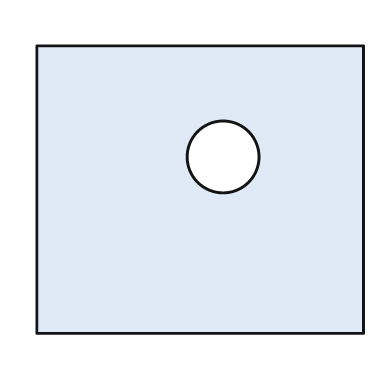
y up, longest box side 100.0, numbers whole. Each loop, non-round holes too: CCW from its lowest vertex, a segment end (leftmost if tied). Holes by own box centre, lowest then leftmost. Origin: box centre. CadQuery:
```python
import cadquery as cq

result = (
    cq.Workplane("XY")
    .moveTo(-50.0, -44.0)
    .lineTo(50.0, -44.0)
    .lineTo(50.0, 44.0)
    .lineTo(-50.0, 44.0)
    .close()
    .moveTo(7.0, 10.0)
    .circle(11.0)
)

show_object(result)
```